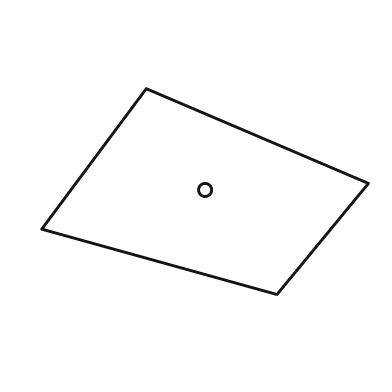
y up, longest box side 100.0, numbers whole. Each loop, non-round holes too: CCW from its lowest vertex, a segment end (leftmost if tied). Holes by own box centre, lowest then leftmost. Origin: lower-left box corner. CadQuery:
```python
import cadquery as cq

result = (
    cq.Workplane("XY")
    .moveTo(72.0, 0.0)
    .lineTo(100.0, 34.0)
    .lineTo(32.0, 63.0)
    .lineTo(0.0, 20.0)
    .close()
    .moveTo(50.0, 32.0)
    .circle(2.0)
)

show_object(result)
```